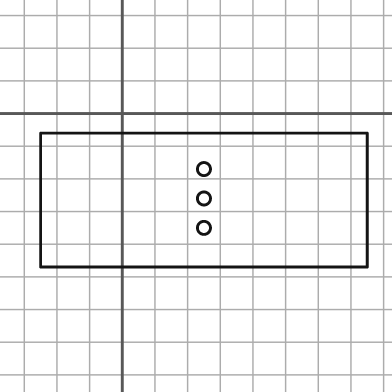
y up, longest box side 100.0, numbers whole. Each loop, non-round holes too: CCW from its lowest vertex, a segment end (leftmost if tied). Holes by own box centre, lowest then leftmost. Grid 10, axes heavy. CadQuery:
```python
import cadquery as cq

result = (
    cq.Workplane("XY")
    .moveTo(-25.0, -47.0)
    .lineTo(75.0, -47.0)
    .lineTo(75.0, -6.0)
    .lineTo(-25.0, -6.0)
    .close()
    .moveTo(25.0, -35.0)
    .circle(2.0)
    .moveTo(25.0, -26.0)
    .circle(2.0)
    .moveTo(25.0, -17.0)
    .circle(2.0)
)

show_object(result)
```